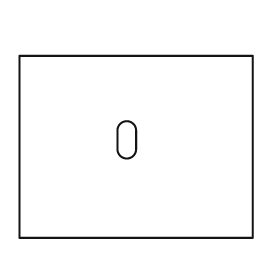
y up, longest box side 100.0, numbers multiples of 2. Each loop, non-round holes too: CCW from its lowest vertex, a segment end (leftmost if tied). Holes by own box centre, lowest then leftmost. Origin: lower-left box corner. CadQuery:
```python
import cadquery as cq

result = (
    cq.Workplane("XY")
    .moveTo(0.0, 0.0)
    .lineTo(100.0, 0.0)
    .lineTo(100.0, 78.0)
    .lineTo(0.0, 78.0)
    .close()
    .moveTo(42.0, 38.0)
    .threePointArc((46.0, 34.0), (50.0, 38.0))
    .lineTo(50.0, 46.0)
    .threePointArc((46.0, 50.0), (42.0, 46.0))
    .close()
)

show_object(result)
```